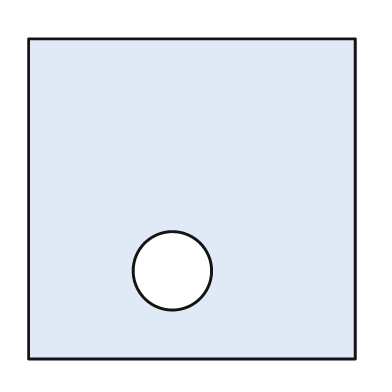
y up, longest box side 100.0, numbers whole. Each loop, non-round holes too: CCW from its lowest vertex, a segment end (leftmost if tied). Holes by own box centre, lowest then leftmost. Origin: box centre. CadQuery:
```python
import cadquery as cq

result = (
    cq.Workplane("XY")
    .moveTo(-50.0, -49.0)
    .lineTo(50.0, -49.0)
    .lineTo(50.0, 49.0)
    .lineTo(-50.0, 49.0)
    .close()
    .moveTo(-6.0, -22.0)
    .circle(12.0)
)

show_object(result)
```